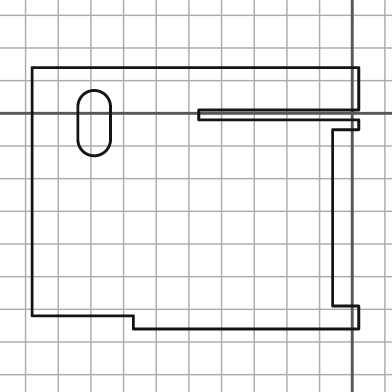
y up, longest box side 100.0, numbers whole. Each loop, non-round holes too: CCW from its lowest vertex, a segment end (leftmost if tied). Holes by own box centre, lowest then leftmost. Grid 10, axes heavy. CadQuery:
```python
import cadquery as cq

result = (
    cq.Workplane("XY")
    .moveTo(-67.0, -66.0)
    .lineTo(2.0, -66.0)
    .lineTo(2.0, -59.0)
    .lineTo(-6.0, -59.0)
    .lineTo(-6.0, -5.0)
    .lineTo(2.0, -5.0)
    .lineTo(2.0, -2.0)
    .lineTo(-47.0, -2.0)
    .lineTo(-47.0, 1.0)
    .lineTo(2.0, 1.0)
    .lineTo(2.0, 14.0)
    .lineTo(-98.0, 14.0)
    .lineTo(-98.0, -62.0)
    .lineTo(-67.0, -62.0)
    .close()
    .moveTo(-84.0, -8.0)
    .threePointArc((-79.0, -13.0), (-74.0, -8.0))
    .lineTo(-74.0, 2.0)
    .threePointArc((-79.0, 7.0), (-84.0, 2.0))
    .close()
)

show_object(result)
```